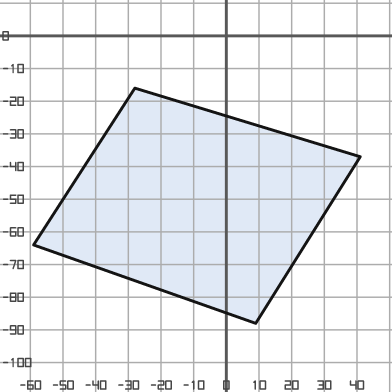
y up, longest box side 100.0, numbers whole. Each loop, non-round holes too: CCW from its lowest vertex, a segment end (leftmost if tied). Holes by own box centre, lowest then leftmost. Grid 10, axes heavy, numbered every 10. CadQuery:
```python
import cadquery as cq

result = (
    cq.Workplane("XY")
    .moveTo(9.0, -88.0)
    .lineTo(41.0, -37.0)
    .lineTo(-28.0, -16.0)
    .lineTo(-59.0, -64.0)
    .close()
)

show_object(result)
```